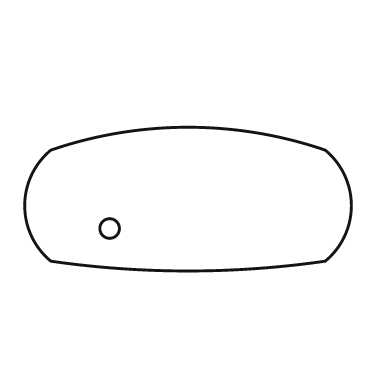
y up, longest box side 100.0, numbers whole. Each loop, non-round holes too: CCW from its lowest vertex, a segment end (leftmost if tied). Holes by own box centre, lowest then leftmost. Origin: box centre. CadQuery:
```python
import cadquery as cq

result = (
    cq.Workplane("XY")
    .moveTo(-42.0, -19.0)
    .threePointArc((0.0, -22.0), (42.0, -19.0))
    .threePointArc((50.0, -2.0), (42.0, 15.0))
    .threePointArc((0.0, 22.0), (-42.0, 15.0))
    .threePointArc((-50.0, -2.0), (-42.0, -19.0))
    .close()
    .moveTo(-24.0, -9.0)
    .circle(3.0)
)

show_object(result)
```